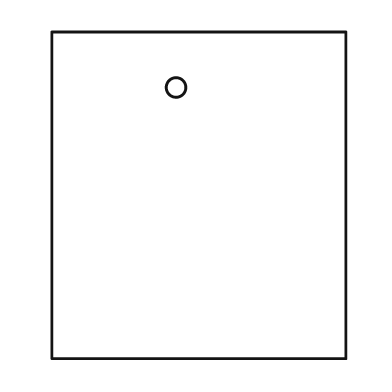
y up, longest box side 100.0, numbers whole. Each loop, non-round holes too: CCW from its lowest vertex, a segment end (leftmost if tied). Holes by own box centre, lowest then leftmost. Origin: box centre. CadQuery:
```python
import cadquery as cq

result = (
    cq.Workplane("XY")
    .moveTo(-45.0, -50.0)
    .lineTo(45.0, -50.0)
    .lineTo(45.0, 50.0)
    .lineTo(-45.0, 50.0)
    .close()
    .moveTo(-7.0, 33.0)
    .circle(3.0)
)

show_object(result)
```